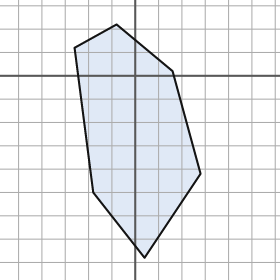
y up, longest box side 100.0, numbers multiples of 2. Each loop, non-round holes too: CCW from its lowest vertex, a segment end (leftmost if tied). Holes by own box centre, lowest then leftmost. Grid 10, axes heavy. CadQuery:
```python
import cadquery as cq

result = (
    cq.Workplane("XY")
    .moveTo(4.0, -78.0)
    .lineTo(28.0, -42.0)
    .lineTo(16.0, 2.0)
    .lineTo(-8.0, 22.0)
    .lineTo(-26.0, 12.0)
    .lineTo(-18.0, -50.0)
    .close()
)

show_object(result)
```